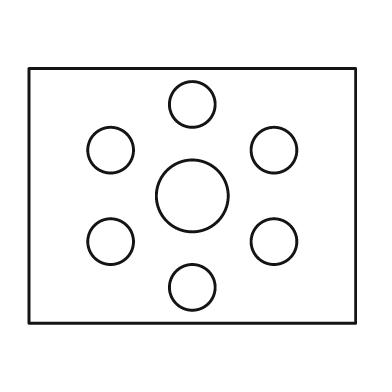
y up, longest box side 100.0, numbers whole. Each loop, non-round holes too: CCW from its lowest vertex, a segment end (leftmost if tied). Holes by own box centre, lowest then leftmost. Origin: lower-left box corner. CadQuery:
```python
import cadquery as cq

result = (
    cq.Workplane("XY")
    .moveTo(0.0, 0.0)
    .lineTo(100.0, 0.0)
    .lineTo(100.0, 78.0)
    .lineTo(0.0, 78.0)
    .close()
    .moveTo(50.0, 11.0)
    .circle(7.0)
    .moveTo(25.0, 25.0)
    .circle(7.0)
    .moveTo(75.0, 25.0)
    .circle(7.0)
    .moveTo(50.0, 39.0)
    .circle(11.0)
    .moveTo(25.0, 53.0)
    .circle(7.0)
    .moveTo(75.0, 53.0)
    .circle(7.0)
    .moveTo(50.0, 67.0)
    .circle(7.0)
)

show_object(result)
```